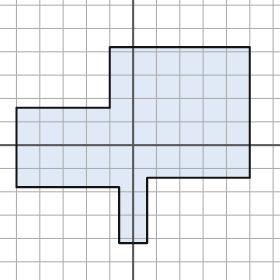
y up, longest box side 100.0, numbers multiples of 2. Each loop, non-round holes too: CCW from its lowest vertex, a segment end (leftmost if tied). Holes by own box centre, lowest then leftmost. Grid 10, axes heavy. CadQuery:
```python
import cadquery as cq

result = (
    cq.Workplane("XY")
    .moveTo(-6.0, -42.0)
    .lineTo(6.0, -42.0)
    .lineTo(6.0, -14.0)
    .lineTo(50.0, -14.0)
    .lineTo(50.0, 42.0)
    .lineTo(-10.0, 42.0)
    .lineTo(-10.0, 16.0)
    .lineTo(-50.0, 16.0)
    .lineTo(-50.0, -18.0)
    .lineTo(-6.0, -18.0)
    .close()
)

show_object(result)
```